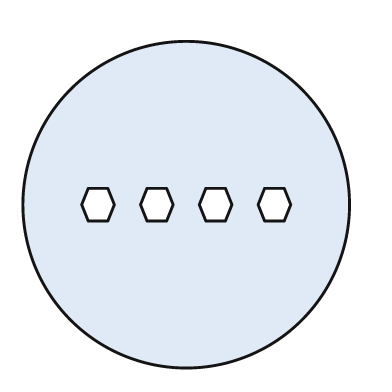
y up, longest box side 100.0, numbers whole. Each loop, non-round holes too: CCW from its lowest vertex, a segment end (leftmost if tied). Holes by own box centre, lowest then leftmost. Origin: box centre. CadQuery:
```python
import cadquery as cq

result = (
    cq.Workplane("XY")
    .moveTo(0.0, 0.0)
    .circle(50.0)
    .moveTo(-30.0, -5.0)
    .lineTo(-24.0, -5.0)
    .lineTo(-22.0, 0.0)
    .lineTo(-24.0, 5.0)
    .lineTo(-30.0, 5.0)
    .lineTo(-32.0, 0.0)
    .close()
    .moveTo(-12.0, -5.0)
    .lineTo(-6.0, -5.0)
    .lineTo(-4.0, 0.0)
    .lineTo(-6.0, 5.0)
    .lineTo(-12.0, 5.0)
    .lineTo(-14.0, 0.0)
    .close()
    .moveTo(6.0, -5.0)
    .lineTo(12.0, -5.0)
    .lineTo(14.0, 0.0)
    .lineTo(12.0, 5.0)
    .lineTo(6.0, 5.0)
    .lineTo(4.0, 0.0)
    .close()
    .moveTo(24.0, -5.0)
    .lineTo(30.0, -5.0)
    .lineTo(32.0, 0.0)
    .lineTo(30.0, 5.0)
    .lineTo(24.0, 5.0)
    .lineTo(22.0, 0.0)
    .close()
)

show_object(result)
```